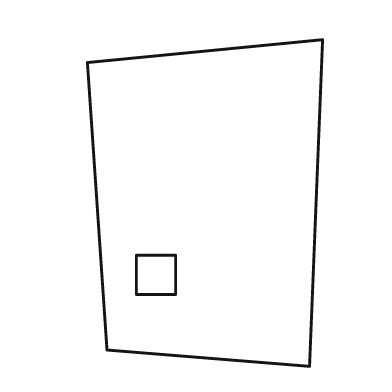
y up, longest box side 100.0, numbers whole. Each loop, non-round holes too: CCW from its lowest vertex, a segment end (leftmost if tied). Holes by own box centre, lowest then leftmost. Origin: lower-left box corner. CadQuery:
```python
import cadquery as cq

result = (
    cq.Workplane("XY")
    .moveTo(68.0, 0.0)
    .lineTo(72.0, 100.0)
    .lineTo(0.0, 93.0)
    .lineTo(6.0, 5.0)
    .close()
    .moveTo(15.0, 22.0)
    .lineTo(27.0, 22.0)
    .lineTo(27.0, 34.0)
    .lineTo(15.0, 34.0)
    .close()
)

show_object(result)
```